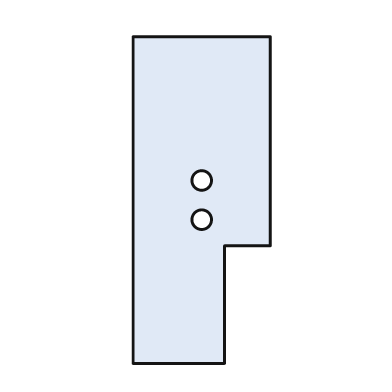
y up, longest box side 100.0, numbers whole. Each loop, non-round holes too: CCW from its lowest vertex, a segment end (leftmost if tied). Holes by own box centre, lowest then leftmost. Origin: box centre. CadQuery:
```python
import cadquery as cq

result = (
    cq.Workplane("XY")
    .moveTo(-21.0, -50.0)
    .lineTo(7.0, -50.0)
    .lineTo(7.0, -14.0)
    .lineTo(21.0, -14.0)
    .lineTo(21.0, 50.0)
    .lineTo(-21.0, 50.0)
    .close()
    .moveTo(0.0, -6.0)
    .circle(3.0)
    .moveTo(0.0, 6.0)
    .circle(3.0)
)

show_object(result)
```